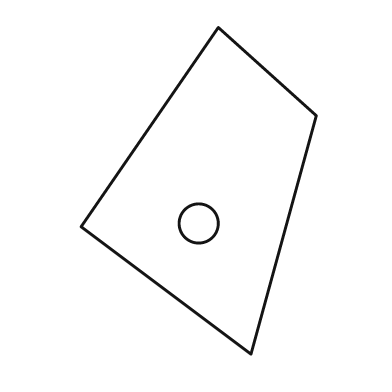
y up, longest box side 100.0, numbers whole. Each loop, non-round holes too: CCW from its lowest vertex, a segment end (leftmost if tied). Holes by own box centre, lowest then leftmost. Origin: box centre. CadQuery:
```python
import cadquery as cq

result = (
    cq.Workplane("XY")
    .moveTo(16.0, -50.0)
    .lineTo(36.0, 23.0)
    .lineTo(6.0, 50.0)
    .lineTo(-36.0, -11.0)
    .close()
    .moveTo(0.0, -10.0)
    .circle(6.0)
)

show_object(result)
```